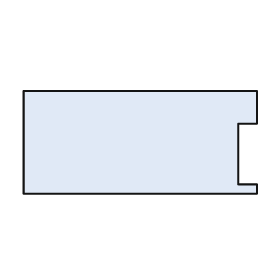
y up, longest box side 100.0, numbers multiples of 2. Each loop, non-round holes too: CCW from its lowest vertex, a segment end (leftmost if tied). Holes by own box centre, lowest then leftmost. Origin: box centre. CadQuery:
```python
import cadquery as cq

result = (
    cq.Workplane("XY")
    .moveTo(-50.0, -22.0)
    .lineTo(50.0, -22.0)
    .lineTo(50.0, -18.0)
    .lineTo(42.0, -18.0)
    .lineTo(42.0, 8.0)
    .lineTo(50.0, 8.0)
    .lineTo(50.0, 22.0)
    .lineTo(-50.0, 22.0)
    .close()
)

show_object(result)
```